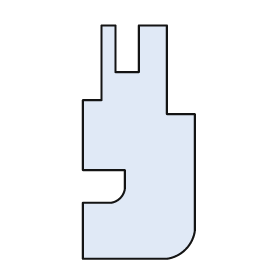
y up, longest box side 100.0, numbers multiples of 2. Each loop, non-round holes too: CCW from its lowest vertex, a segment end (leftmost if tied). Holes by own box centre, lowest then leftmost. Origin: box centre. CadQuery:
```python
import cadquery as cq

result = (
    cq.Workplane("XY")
    .moveTo(-24.0, -50.0)
    .lineTo(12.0, -50.0)
    .threePointArc((20.0, -46.0), (24.0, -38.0))
    .lineTo(24.0, 12.0)
    .lineTo(12.0, 12.0)
    .lineTo(12.0, 50.0)
    .lineTo(0.0, 50.0)
    .lineTo(0.0, 30.0)
    .lineTo(-10.0, 30.0)
    .lineTo(-10.0, 50.0)
    .lineTo(-16.0, 50.0)
    .lineTo(-16.0, 18.0)
    .lineTo(-24.0, 18.0)
    .lineTo(-24.0, -12.0)
    .lineTo(-6.0, -12.0)
    .lineTo(-6.0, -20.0)
    .threePointArc((-8.0, -24.0), (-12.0, -26.0))
    .lineTo(-24.0, -26.0)
    .close()
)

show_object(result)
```